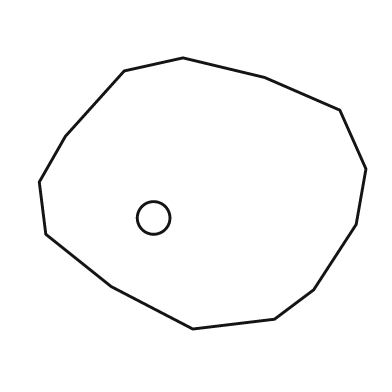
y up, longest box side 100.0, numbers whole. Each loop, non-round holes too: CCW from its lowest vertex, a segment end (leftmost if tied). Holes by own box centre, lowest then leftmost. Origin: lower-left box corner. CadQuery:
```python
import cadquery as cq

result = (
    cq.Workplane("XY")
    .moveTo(47.0, 0.0)
    .lineTo(72.0, 3.0)
    .lineTo(84.0, 12.0)
    .lineTo(97.0, 32.0)
    .lineTo(100.0, 49.0)
    .lineTo(92.0, 67.0)
    .lineTo(69.0, 77.0)
    .lineTo(44.0, 83.0)
    .lineTo(26.0, 79.0)
    .lineTo(8.0, 59.0)
    .lineTo(0.0, 45.0)
    .lineTo(2.0, 29.0)
    .lineTo(22.0, 13.0)
    .close()
    .moveTo(35.0, 34.0)
    .circle(5.0)
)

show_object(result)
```